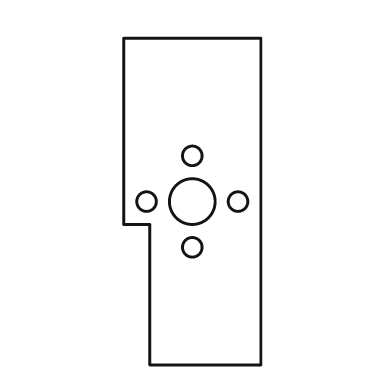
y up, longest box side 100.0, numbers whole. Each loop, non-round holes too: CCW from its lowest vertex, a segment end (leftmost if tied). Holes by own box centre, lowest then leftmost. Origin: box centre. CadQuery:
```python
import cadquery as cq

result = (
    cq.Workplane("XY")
    .moveTo(-13.0, -50.0)
    .lineTo(21.0, -50.0)
    .lineTo(21.0, 50.0)
    .lineTo(-21.0, 50.0)
    .lineTo(-21.0, -7.0)
    .lineTo(-13.0, -7.0)
    .close()
    .moveTo(0.0, -14.0)
    .circle(3.0)
    .moveTo(-14.0, 0.0)
    .circle(3.0)
    .moveTo(0.0, 0.0)
    .circle(7.0)
    .moveTo(14.0, 0.0)
    .circle(3.0)
    .moveTo(0.0, 14.0)
    .circle(3.0)
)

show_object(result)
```